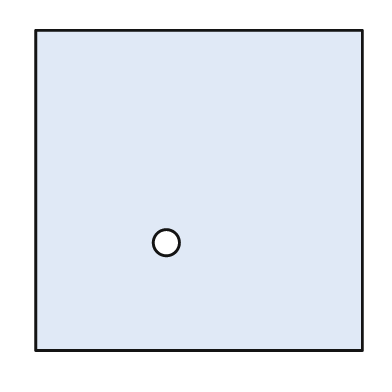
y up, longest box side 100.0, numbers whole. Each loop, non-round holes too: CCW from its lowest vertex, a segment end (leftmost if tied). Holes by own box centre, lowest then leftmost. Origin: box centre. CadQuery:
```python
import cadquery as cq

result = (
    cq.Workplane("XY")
    .moveTo(-50.0, -49.0)
    .lineTo(50.0, -49.0)
    .lineTo(50.0, 49.0)
    .lineTo(-50.0, 49.0)
    .close()
    .moveTo(-10.0, -16.0)
    .circle(4.0)
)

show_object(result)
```